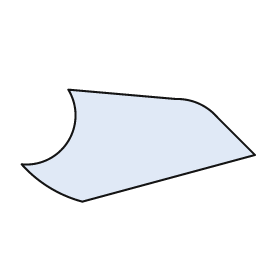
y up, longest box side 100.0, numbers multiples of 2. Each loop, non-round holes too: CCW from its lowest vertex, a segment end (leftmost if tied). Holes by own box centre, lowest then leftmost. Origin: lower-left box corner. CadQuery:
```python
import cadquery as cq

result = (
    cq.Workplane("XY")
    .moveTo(26.0, 0.0)
    .lineTo(100.0, 20.0)
    .lineTo(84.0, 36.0)
    .threePointArc((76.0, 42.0), (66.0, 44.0))
    .lineTo(20.0, 48.0)
    .threePointArc((20.0, 26.0), (0.0, 16.0))
    .threePointArc((12.0, 6.0), (26.0, 0.0))
    .close()
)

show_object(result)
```